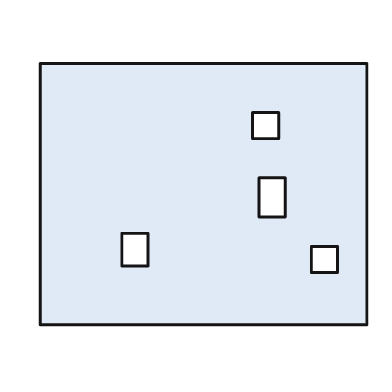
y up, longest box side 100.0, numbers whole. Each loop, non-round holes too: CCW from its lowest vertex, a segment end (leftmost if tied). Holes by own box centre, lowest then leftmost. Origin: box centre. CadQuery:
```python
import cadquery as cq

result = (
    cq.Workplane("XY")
    .moveTo(-50.0, -40.0)
    .lineTo(50.0, -40.0)
    .lineTo(50.0, 40.0)
    .lineTo(-50.0, 40.0)
    .close()
    .moveTo(33.0, -24.0)
    .lineTo(41.0, -24.0)
    .lineTo(41.0, -16.0)
    .lineTo(33.0, -16.0)
    .close()
    .moveTo(-25.0, -22.0)
    .lineTo(-17.0, -22.0)
    .lineTo(-17.0, -12.0)
    .lineTo(-25.0, -12.0)
    .close()
    .moveTo(17.0, -7.0)
    .lineTo(25.0, -7.0)
    .lineTo(25.0, 5.0)
    .lineTo(17.0, 5.0)
    .close()
    .moveTo(15.0, 17.0)
    .lineTo(23.0, 17.0)
    .lineTo(23.0, 25.0)
    .lineTo(15.0, 25.0)
    .close()
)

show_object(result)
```